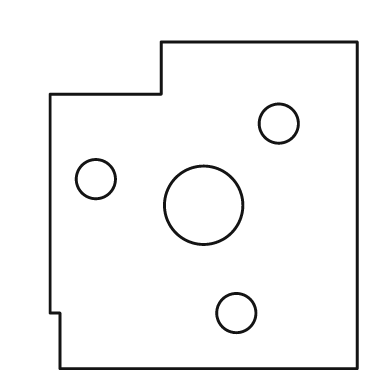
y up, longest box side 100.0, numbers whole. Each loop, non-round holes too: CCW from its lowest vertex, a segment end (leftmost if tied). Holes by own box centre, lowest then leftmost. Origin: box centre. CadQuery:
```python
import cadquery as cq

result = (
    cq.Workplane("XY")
    .moveTo(-44.0, -50.0)
    .lineTo(47.0, -50.0)
    .lineTo(47.0, 50.0)
    .lineTo(-13.0, 50.0)
    .lineTo(-13.0, 34.0)
    .lineTo(-47.0, 34.0)
    .lineTo(-47.0, -33.0)
    .lineTo(-44.0, -33.0)
    .close()
    .moveTo(10.0, -33.0)
    .circle(6.0)
    .moveTo(0.0, 0.0)
    .circle(12.0)
    .moveTo(-33.0, 8.0)
    .circle(6.0)
    .moveTo(23.0, 25.0)
    .circle(6.0)
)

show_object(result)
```